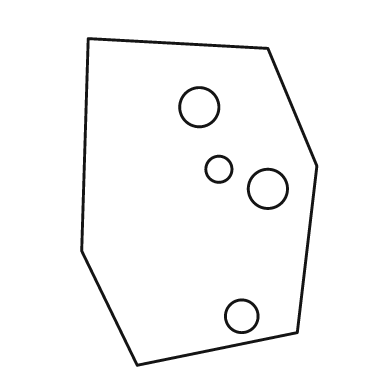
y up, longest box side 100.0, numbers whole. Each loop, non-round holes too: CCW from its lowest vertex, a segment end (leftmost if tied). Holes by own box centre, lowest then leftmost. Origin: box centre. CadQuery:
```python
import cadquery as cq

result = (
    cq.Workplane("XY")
    .moveTo(-19.0, -50.0)
    .lineTo(30.0, -40.0)
    .lineTo(36.0, 11.0)
    .lineTo(21.0, 47.0)
    .lineTo(-34.0, 50.0)
    .lineTo(-36.0, -15.0)
    .close()
    .moveTo(13.0, -35.0)
    .circle(5.0)
    .moveTo(21.0, 4.0)
    .circle(6.0)
    .moveTo(6.0, 10.0)
    .circle(4.0)
    .moveTo(0.0, 29.0)
    .circle(6.0)
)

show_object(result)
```